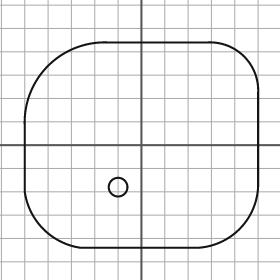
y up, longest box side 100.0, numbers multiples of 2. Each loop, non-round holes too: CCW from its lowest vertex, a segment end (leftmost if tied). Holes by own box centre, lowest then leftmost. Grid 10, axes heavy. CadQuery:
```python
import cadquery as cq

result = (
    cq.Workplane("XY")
    .moveTo(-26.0, -44.0)
    .lineTo(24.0, -44.0)
    .threePointArc((42.0, -36.0), (50.0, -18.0))
    .lineTo(50.0, 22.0)
    .threePointArc((44.0, 38.0), (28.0, 44.0))
    .lineTo(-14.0, 44.0)
    .threePointArc((-40.0, 34.0), (-50.0, 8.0))
    .lineTo(-50.0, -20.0)
    .threePointArc((-42.0, -36.0), (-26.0, -44.0))
    .close()
    .moveTo(-10.0, -18.0)
    .circle(4.0)
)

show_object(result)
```